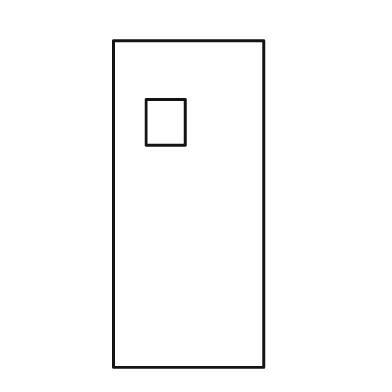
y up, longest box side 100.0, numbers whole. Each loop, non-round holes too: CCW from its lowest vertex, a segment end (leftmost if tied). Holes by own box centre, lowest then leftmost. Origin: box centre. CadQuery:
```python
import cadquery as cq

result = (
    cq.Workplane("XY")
    .moveTo(-23.0, -50.0)
    .lineTo(23.0, -50.0)
    .lineTo(23.0, 50.0)
    .lineTo(-23.0, 50.0)
    .close()
    .moveTo(-13.0, 18.0)
    .lineTo(-1.0, 18.0)
    .lineTo(-1.0, 32.0)
    .lineTo(-13.0, 32.0)
    .close()
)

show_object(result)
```